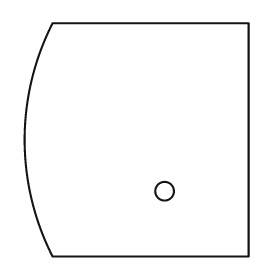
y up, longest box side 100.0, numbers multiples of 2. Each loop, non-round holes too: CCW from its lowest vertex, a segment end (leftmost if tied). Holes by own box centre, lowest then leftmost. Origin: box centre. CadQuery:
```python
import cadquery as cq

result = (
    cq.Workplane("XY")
    .moveTo(-36.0, -50.0)
    .lineTo(48.0, -50.0)
    .lineTo(48.0, 50.0)
    .lineTo(-36.0, 50.0)
    .threePointArc((-48.0, 0.0), (-36.0, -50.0))
    .close()
    .moveTo(12.0, -22.0)
    .circle(4.0)
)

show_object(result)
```